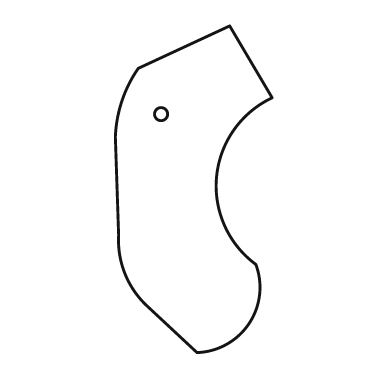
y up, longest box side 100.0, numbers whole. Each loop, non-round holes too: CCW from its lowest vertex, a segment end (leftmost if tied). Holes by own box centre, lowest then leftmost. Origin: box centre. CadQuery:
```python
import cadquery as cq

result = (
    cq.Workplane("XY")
    .moveTo(1.0, -50.0)
    .threePointArc((17.0, -41.0), (19.0, -23.0))
    .threePointArc((7.0, 4.0), (24.0, 28.0))
    .lineTo(11.0, 50.0)
    .lineTo(-17.0, 37.0)
    .threePointArc((-22.0, 27.0), (-24.0, 16.0))
    .lineTo(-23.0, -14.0)
    .threePointArc((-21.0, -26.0), (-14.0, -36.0))
    .close()
    .moveTo(-10.0, 23.0)
    .circle(2.0)
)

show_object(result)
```